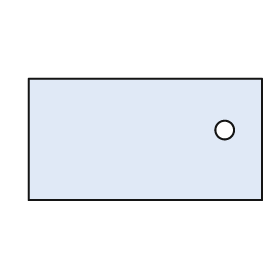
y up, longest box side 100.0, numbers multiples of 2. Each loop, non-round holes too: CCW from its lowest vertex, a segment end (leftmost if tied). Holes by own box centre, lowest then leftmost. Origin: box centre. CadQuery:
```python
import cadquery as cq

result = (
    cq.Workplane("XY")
    .moveTo(-50.0, -26.0)
    .lineTo(50.0, -26.0)
    .lineTo(50.0, 26.0)
    .lineTo(-50.0, 26.0)
    .close()
    .moveTo(34.0, 4.0)
    .circle(4.0)
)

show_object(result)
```